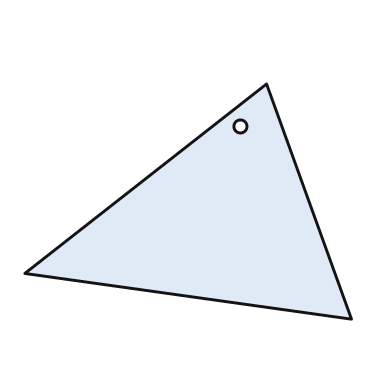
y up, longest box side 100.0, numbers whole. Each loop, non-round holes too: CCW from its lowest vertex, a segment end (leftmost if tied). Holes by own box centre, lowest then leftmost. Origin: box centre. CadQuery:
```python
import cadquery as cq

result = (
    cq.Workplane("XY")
    .moveTo(50.0, -36.0)
    .lineTo(24.0, 36.0)
    .lineTo(-50.0, -22.0)
    .close()
    .moveTo(16.0, 23.0)
    .circle(2.0)
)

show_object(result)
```